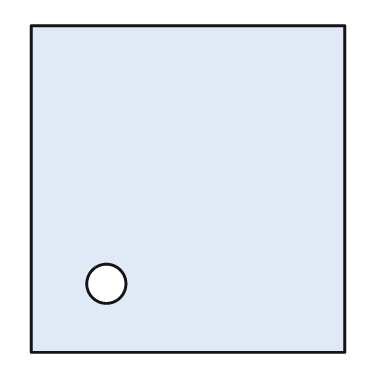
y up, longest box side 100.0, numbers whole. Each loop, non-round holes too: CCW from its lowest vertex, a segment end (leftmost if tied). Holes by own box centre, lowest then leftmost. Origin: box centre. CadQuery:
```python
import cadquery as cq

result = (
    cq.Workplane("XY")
    .moveTo(-48.0, -50.0)
    .lineTo(48.0, -50.0)
    .lineTo(48.0, 50.0)
    .lineTo(-48.0, 50.0)
    .close()
    .moveTo(-25.0, -29.0)
    .circle(6.0)
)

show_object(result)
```